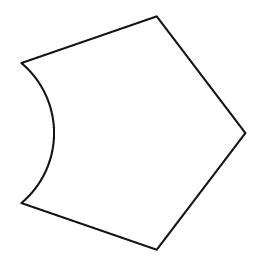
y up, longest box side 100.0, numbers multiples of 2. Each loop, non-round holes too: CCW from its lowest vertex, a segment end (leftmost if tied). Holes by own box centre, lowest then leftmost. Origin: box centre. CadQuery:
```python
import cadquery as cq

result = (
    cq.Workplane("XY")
    .moveTo(10.0, -50.0)
    .lineTo(48.0, 0.0)
    .lineTo(10.0, 50.0)
    .lineTo(-48.0, 30.0)
    .threePointArc((-34.0, 0.0), (-48.0, -30.0))
    .close()
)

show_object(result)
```